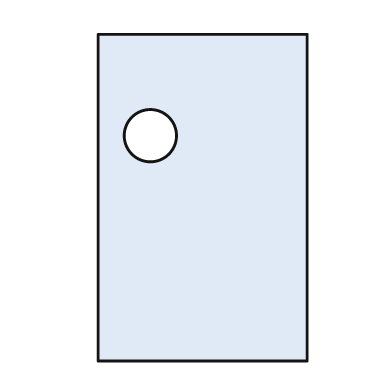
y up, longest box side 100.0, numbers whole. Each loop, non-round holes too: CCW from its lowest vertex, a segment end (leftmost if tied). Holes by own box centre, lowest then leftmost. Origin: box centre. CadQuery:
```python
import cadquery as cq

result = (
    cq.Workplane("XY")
    .moveTo(-32.0, -50.0)
    .lineTo(32.0, -50.0)
    .lineTo(32.0, 50.0)
    .lineTo(-32.0, 50.0)
    .close()
    .moveTo(-16.0, 19.0)
    .circle(8.0)
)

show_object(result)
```